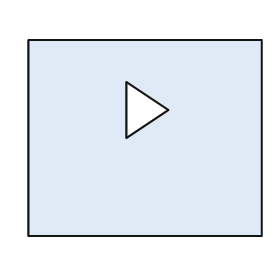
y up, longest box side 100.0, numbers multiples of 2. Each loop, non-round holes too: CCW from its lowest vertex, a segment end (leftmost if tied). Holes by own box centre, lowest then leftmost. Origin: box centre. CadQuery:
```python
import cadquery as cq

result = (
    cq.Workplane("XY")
    .moveTo(-50.0, -42.0)
    .lineTo(50.0, -42.0)
    .lineTo(50.0, 42.0)
    .lineTo(-50.0, 42.0)
    .close()
    .moveTo(-8.0, 0.0)
    .lineTo(10.0, 12.0)
    .lineTo(-8.0, 24.0)
    .close()
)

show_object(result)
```